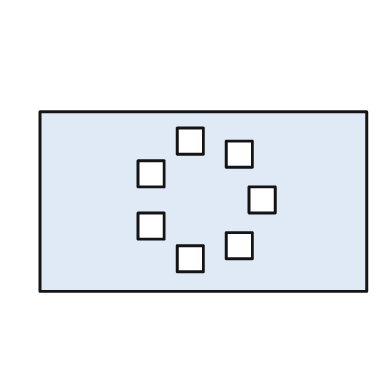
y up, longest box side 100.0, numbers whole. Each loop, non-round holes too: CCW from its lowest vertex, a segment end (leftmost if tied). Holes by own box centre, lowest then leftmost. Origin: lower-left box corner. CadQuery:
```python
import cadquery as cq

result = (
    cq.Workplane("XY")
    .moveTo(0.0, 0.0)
    .lineTo(100.0, 0.0)
    .lineTo(100.0, 55.0)
    .lineTo(0.0, 55.0)
    .close()
    .moveTo(42.0, 6.0)
    .lineTo(50.0, 6.0)
    .lineTo(50.0, 14.0)
    .lineTo(42.0, 14.0)
    .close()
    .moveTo(57.0, 10.0)
    .lineTo(65.0, 10.0)
    .lineTo(65.0, 18.0)
    .lineTo(57.0, 18.0)
    .close()
    .moveTo(30.0, 16.0)
    .lineTo(38.0, 16.0)
    .lineTo(38.0, 24.0)
    .lineTo(30.0, 24.0)
    .close()
    .moveTo(64.0, 24.0)
    .lineTo(72.0, 24.0)
    .lineTo(72.0, 32.0)
    .lineTo(64.0, 32.0)
    .close()
    .moveTo(30.0, 32.0)
    .lineTo(38.0, 32.0)
    .lineTo(38.0, 40.0)
    .lineTo(30.0, 40.0)
    .close()
    .moveTo(57.0, 38.0)
    .lineTo(65.0, 38.0)
    .lineTo(65.0, 46.0)
    .lineTo(57.0, 46.0)
    .close()
    .moveTo(42.0, 42.0)
    .lineTo(50.0, 42.0)
    .lineTo(50.0, 50.0)
    .lineTo(42.0, 50.0)
    .close()
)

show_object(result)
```